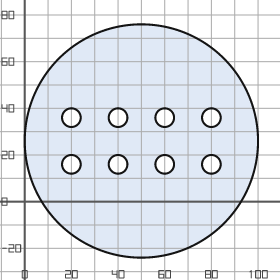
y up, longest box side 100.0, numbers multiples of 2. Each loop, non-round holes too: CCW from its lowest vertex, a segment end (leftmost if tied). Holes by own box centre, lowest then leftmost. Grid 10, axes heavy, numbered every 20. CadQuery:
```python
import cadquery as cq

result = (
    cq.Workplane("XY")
    .moveTo(50.0, 26.0)
    .circle(50.0)
    .moveTo(20.0, 16.0)
    .circle(4.0)
    .moveTo(40.0, 16.0)
    .circle(4.0)
    .moveTo(60.0, 16.0)
    .circle(4.0)
    .moveTo(80.0, 16.0)
    .circle(4.0)
    .moveTo(20.0, 36.0)
    .circle(4.0)
    .moveTo(40.0, 36.0)
    .circle(4.0)
    .moveTo(60.0, 36.0)
    .circle(4.0)
    .moveTo(80.0, 36.0)
    .circle(4.0)
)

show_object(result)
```